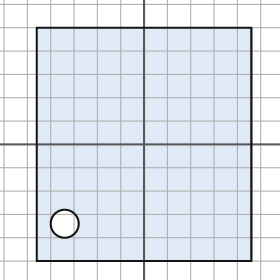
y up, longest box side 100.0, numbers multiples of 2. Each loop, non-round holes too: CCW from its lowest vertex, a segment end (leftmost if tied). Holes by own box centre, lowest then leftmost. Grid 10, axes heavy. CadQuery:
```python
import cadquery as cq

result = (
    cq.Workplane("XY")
    .moveTo(-46.0, -50.0)
    .lineTo(46.0, -50.0)
    .lineTo(46.0, 50.0)
    .lineTo(-46.0, 50.0)
    .close()
    .moveTo(-34.0, -34.0)
    .circle(6.0)
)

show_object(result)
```